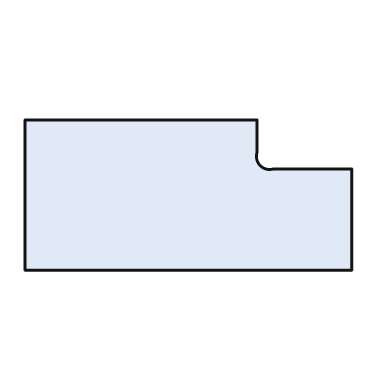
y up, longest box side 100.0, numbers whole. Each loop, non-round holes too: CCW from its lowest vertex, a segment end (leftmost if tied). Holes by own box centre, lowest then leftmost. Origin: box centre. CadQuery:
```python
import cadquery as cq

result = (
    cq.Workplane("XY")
    .moveTo(-50.0, -23.0)
    .lineTo(50.0, -23.0)
    .lineTo(50.0, 8.0)
    .lineTo(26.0, 8.0)
    .threePointArc((22.0, 9.0), (21.0, 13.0))
    .lineTo(21.0, 23.0)
    .lineTo(-50.0, 23.0)
    .close()
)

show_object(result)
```